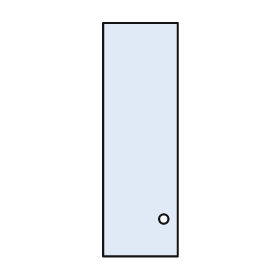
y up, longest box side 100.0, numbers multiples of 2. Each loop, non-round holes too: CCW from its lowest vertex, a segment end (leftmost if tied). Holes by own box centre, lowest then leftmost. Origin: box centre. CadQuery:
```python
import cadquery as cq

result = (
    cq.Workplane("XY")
    .moveTo(-16.0, -50.0)
    .lineTo(16.0, -50.0)
    .lineTo(16.0, 50.0)
    .lineTo(-16.0, 50.0)
    .close()
    .moveTo(10.0, -34.0)
    .circle(2.0)
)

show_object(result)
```